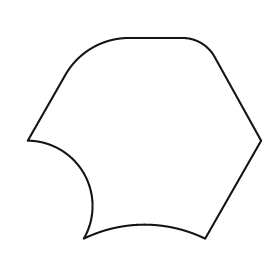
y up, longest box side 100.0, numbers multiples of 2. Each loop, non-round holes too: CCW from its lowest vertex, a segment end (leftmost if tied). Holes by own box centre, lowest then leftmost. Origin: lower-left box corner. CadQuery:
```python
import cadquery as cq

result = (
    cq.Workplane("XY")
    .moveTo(24.0, 0.0)
    .threePointArc((50.0, 6.0), (76.0, 0.0))
    .lineTo(100.0, 42.0)
    .lineTo(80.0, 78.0)
    .threePointArc((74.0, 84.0), (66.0, 86.0))
    .lineTo(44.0, 86.0)
    .threePointArc((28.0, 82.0), (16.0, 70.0))
    .lineTo(0.0, 42.0)
    .threePointArc((24.0, 28.0), (24.0, 0.0))
    .close()
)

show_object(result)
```